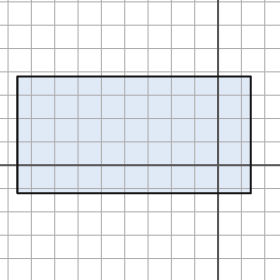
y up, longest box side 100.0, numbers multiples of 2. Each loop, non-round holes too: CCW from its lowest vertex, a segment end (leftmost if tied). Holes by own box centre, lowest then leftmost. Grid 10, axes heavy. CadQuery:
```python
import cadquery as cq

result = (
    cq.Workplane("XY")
    .moveTo(-86.0, -12.0)
    .lineTo(14.0, -12.0)
    .lineTo(14.0, 38.0)
    .lineTo(-86.0, 38.0)
    .close()
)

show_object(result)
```